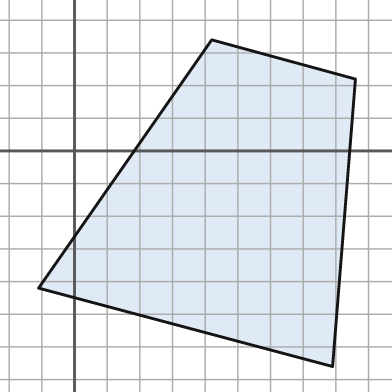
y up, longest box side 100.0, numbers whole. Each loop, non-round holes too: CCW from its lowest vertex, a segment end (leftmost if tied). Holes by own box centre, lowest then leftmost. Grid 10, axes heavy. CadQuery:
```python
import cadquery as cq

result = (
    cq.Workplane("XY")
    .moveTo(79.0, -66.0)
    .lineTo(86.0, 22.0)
    .lineTo(42.0, 34.0)
    .lineTo(-11.0, -42.0)
    .close()
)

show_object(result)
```